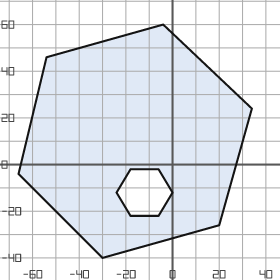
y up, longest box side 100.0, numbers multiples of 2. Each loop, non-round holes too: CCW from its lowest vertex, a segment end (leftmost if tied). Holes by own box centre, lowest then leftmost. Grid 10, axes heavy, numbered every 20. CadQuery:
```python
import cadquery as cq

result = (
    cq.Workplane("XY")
    .moveTo(-30.0, -40.0)
    .lineTo(20.0, -26.0)
    .lineTo(34.0, 24.0)
    .lineTo(-4.0, 60.0)
    .lineTo(-54.0, 46.0)
    .lineTo(-66.0, -4.0)
    .close()
    .moveTo(-18.0, -22.0)
    .lineTo(-6.0, -22.0)
    .lineTo(0.0, -12.0)
    .lineTo(-6.0, -2.0)
    .lineTo(-18.0, -2.0)
    .lineTo(-24.0, -12.0)
    .close()
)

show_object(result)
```